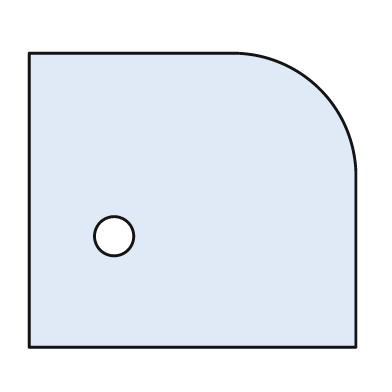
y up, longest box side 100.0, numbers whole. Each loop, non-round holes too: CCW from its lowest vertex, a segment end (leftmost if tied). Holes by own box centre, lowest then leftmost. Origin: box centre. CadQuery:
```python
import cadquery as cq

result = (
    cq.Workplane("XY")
    .moveTo(-50.0, -45.0)
    .lineTo(50.0, -45.0)
    .lineTo(50.0, 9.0)
    .threePointArc((39.0, 34.0), (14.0, 45.0))
    .lineTo(-50.0, 45.0)
    .close()
    .moveTo(-24.0, -11.0)
    .circle(6.0)
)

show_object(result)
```